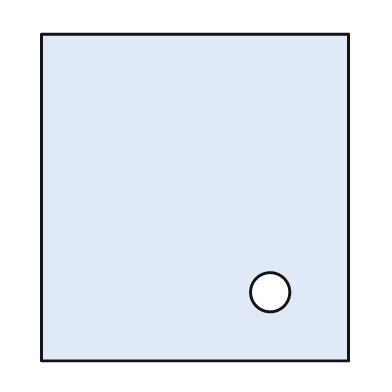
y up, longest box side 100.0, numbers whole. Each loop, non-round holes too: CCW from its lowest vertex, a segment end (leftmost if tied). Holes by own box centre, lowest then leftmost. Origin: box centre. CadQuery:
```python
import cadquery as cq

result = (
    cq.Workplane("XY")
    .moveTo(-47.0, -50.0)
    .lineTo(47.0, -50.0)
    .lineTo(47.0, 50.0)
    .lineTo(-47.0, 50.0)
    .close()
    .moveTo(23.0, -29.0)
    .circle(6.0)
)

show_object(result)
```